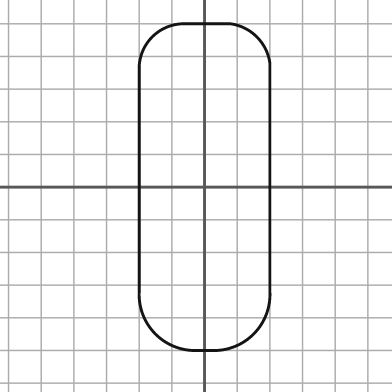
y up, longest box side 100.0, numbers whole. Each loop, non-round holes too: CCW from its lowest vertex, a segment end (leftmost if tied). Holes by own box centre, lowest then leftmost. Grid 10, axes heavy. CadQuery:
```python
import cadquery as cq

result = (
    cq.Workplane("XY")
    .moveTo(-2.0, -50.0)
    .lineTo(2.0, -50.0)
    .threePointArc((15.0, -45.0), (20.0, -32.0))
    .lineTo(20.0, 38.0)
    .threePointArc((16.0, 46.0), (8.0, 50.0))
    .lineTo(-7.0, 50.0)
    .threePointArc((-16.0, 46.0), (-20.0, 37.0))
    .lineTo(-20.0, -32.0)
    .threePointArc((-15.0, -45.0), (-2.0, -50.0))
    .close()
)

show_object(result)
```